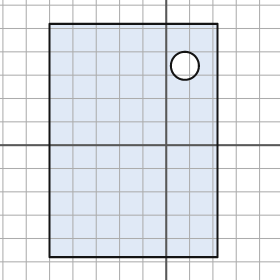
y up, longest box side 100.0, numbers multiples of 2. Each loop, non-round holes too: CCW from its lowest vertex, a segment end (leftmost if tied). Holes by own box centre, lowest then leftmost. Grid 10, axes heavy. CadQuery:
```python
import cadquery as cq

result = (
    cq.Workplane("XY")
    .moveTo(-50.0, -48.0)
    .lineTo(22.0, -48.0)
    .lineTo(22.0, 52.0)
    .lineTo(-50.0, 52.0)
    .close()
    .moveTo(8.0, 34.0)
    .circle(6.0)
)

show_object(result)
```